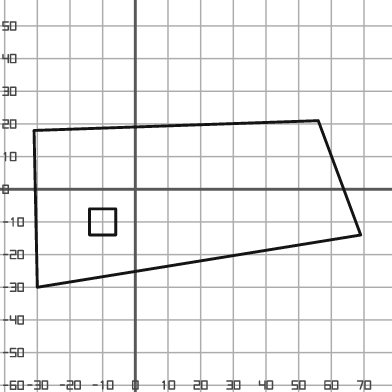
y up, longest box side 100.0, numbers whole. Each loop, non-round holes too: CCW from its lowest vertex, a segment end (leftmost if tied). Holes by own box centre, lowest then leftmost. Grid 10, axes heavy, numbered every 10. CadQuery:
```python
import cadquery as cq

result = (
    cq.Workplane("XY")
    .moveTo(-30.0, -30.0)
    .lineTo(69.0, -14.0)
    .lineTo(56.0, 21.0)
    .lineTo(-31.0, 18.0)
    .close()
    .moveTo(-14.0, -14.0)
    .lineTo(-6.0, -14.0)
    .lineTo(-6.0, -6.0)
    .lineTo(-14.0, -6.0)
    .close()
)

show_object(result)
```